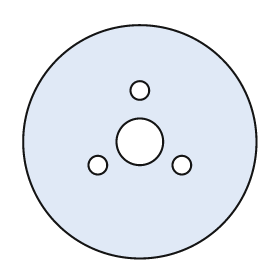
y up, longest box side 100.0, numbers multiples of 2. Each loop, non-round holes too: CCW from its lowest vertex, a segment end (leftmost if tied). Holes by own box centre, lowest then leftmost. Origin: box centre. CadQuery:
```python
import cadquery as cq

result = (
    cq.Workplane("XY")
    .moveTo(0.0, 0.0)
    .circle(50.0)
    .moveTo(-18.0, -10.0)
    .circle(4.0)
    .moveTo(18.0, -10.0)
    .circle(4.0)
    .moveTo(0.0, 0.0)
    .circle(10.0)
    .moveTo(0.0, 22.0)
    .circle(4.0)
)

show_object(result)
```